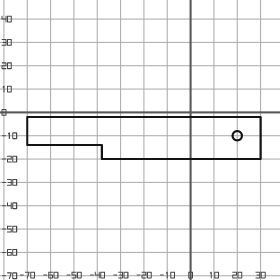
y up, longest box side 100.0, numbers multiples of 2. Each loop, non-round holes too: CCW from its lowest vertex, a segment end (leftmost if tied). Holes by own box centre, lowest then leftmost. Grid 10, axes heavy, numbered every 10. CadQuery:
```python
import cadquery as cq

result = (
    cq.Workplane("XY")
    .moveTo(-38.0, -20.0)
    .lineTo(30.0, -20.0)
    .lineTo(30.0, -2.0)
    .lineTo(-70.0, -2.0)
    .lineTo(-70.0, -14.0)
    .lineTo(-38.0, -14.0)
    .close()
    .moveTo(20.0, -10.0)
    .circle(2.0)
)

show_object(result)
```